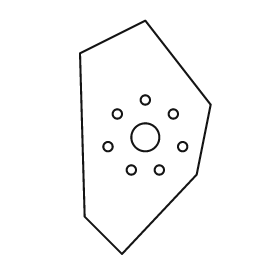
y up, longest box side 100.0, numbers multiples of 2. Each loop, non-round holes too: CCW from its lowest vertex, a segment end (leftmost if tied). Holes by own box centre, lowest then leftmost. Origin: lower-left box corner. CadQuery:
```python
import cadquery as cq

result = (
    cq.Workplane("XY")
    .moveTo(18.0, 0.0)
    .lineTo(50.0, 34.0)
    .lineTo(56.0, 64.0)
    .lineTo(28.0, 100.0)
    .lineTo(0.0, 86.0)
    .lineTo(2.0, 16.0)
    .close()
    .moveTo(22.0, 36.0)
    .circle(2.0)
    .moveTo(34.0, 36.0)
    .circle(2.0)
    .moveTo(12.0, 46.0)
    .circle(2.0)
    .moveTo(44.0, 46.0)
    .circle(2.0)
    .moveTo(28.0, 50.0)
    .circle(6.0)
    .moveTo(16.0, 60.0)
    .circle(2.0)
    .moveTo(40.0, 60.0)
    .circle(2.0)
    .moveTo(28.0, 66.0)
    .circle(2.0)
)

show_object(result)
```